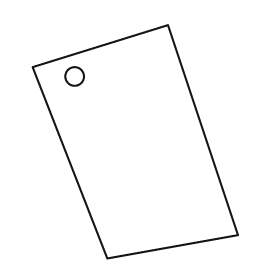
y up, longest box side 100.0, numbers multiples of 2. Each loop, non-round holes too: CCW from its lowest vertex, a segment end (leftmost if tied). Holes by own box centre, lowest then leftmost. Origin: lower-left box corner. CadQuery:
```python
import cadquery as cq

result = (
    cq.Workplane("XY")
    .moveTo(32.0, 0.0)
    .lineTo(88.0, 10.0)
    .lineTo(58.0, 100.0)
    .lineTo(0.0, 82.0)
    .close()
    .moveTo(18.0, 78.0)
    .circle(4.0)
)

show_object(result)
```